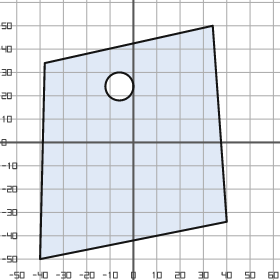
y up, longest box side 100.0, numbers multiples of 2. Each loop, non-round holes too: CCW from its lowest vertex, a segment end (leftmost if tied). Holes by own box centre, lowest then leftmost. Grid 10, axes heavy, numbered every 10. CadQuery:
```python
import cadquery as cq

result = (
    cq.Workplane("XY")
    .moveTo(-40.0, -50.0)
    .lineTo(40.0, -34.0)
    .lineTo(34.0, 50.0)
    .lineTo(-38.0, 34.0)
    .close()
    .moveTo(-6.0, 24.0)
    .circle(6.0)
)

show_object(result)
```